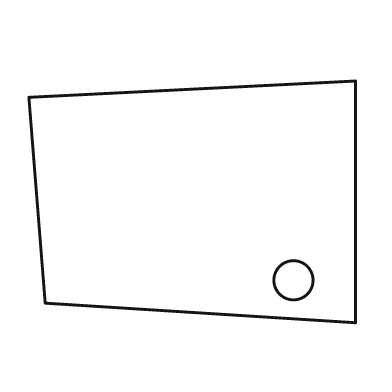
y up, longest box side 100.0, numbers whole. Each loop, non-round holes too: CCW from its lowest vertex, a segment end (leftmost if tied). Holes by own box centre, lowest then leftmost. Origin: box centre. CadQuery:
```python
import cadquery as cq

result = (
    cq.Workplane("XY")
    .moveTo(50.0, -37.0)
    .lineTo(50.0, 37.0)
    .lineTo(-50.0, 32.0)
    .lineTo(-45.0, -31.0)
    .close()
    .moveTo(31.0, -24.0)
    .circle(6.0)
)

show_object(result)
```